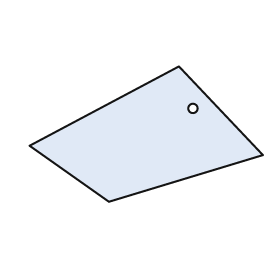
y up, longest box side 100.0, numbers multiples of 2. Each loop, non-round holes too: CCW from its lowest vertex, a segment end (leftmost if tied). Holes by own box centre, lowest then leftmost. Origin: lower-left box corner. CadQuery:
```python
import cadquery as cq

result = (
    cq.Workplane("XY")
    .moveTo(34.0, 0.0)
    .lineTo(100.0, 20.0)
    .lineTo(64.0, 58.0)
    .lineTo(0.0, 24.0)
    .close()
    .moveTo(70.0, 40.0)
    .circle(2.0)
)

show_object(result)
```